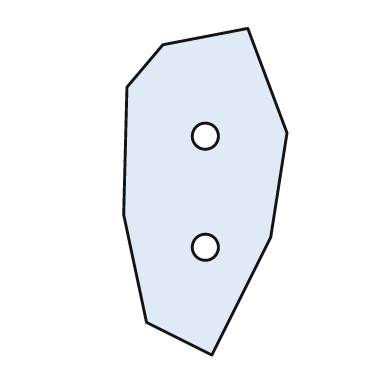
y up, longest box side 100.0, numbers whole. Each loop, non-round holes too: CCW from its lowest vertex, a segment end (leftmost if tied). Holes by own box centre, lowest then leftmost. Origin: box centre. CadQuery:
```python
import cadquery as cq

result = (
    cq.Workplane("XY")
    .moveTo(2.0, -50.0)
    .lineTo(20.0, -14.0)
    .lineTo(25.0, 18.0)
    .lineTo(13.0, 50.0)
    .lineTo(-13.0, 45.0)
    .lineTo(-24.0, 32.0)
    .lineTo(-25.0, -7.0)
    .lineTo(-18.0, -40.0)
    .close()
    .moveTo(0.0, -17.0)
    .circle(4.0)
    .moveTo(0.0, 17.0)
    .circle(4.0)
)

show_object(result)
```